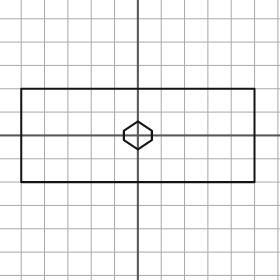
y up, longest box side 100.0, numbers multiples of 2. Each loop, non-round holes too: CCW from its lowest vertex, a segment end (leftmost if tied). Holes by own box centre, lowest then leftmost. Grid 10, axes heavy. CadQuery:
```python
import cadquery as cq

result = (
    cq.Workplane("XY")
    .moveTo(-50.0, -20.0)
    .lineTo(50.0, -20.0)
    .lineTo(50.0, 20.0)
    .lineTo(-50.0, 20.0)
    .close()
    .moveTo(0.0, -6.0)
    .lineTo(6.0, -2.0)
    .lineTo(6.0, 2.0)
    .lineTo(0.0, 6.0)
    .lineTo(-6.0, 2.0)
    .lineTo(-6.0, -2.0)
    .close()
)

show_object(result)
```